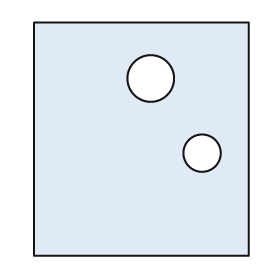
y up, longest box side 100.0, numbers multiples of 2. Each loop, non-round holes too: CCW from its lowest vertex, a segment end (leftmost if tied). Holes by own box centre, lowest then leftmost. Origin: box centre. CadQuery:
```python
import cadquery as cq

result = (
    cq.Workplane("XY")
    .moveTo(-46.0, -50.0)
    .lineTo(46.0, -50.0)
    .lineTo(46.0, 50.0)
    .lineTo(-46.0, 50.0)
    .close()
    .moveTo(26.0, -6.0)
    .circle(8.0)
    .moveTo(4.0, 26.0)
    .circle(10.0)
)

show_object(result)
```